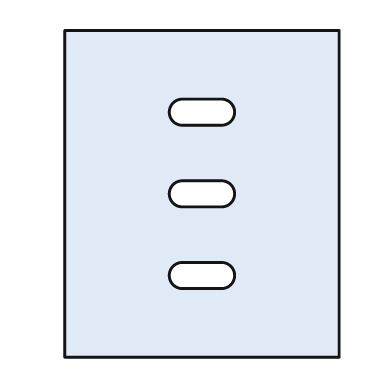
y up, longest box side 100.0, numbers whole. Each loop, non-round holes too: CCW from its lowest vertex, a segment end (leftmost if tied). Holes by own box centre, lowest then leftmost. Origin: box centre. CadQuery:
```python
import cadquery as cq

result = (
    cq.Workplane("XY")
    .moveTo(-42.0, -50.0)
    .lineTo(42.0, -50.0)
    .lineTo(42.0, 50.0)
    .lineTo(-42.0, 50.0)
    .close()
    .moveTo(-6.0, -29.0)
    .lineTo(6.0, -29.0)
    .threePointArc((10.0, -25.0), (6.0, -21.0))
    .lineTo(-6.0, -21.0)
    .threePointArc((-10.0, -25.0), (-6.0, -29.0))
    .close()
    .moveTo(-6.0, -4.0)
    .lineTo(6.0, -4.0)
    .threePointArc((10.0, 0.0), (6.0, 4.0))
    .lineTo(-6.0, 4.0)
    .threePointArc((-10.0, 0.0), (-6.0, -4.0))
    .close()
    .moveTo(-6.0, 21.0)
    .lineTo(6.0, 21.0)
    .threePointArc((10.0, 25.0), (6.0, 29.0))
    .lineTo(-6.0, 29.0)
    .threePointArc((-10.0, 25.0), (-6.0, 21.0))
    .close()
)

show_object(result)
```